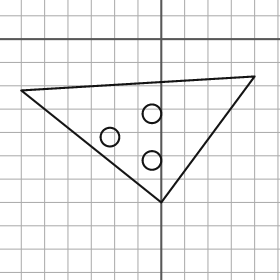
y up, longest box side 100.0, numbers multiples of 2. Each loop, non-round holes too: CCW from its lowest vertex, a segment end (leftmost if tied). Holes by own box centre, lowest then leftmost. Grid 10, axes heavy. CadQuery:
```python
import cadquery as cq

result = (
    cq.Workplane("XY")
    .moveTo(0.0, -70.0)
    .lineTo(40.0, -16.0)
    .lineTo(-60.0, -22.0)
    .close()
    .moveTo(-4.0, -52.0)
    .circle(4.0)
    .moveTo(-22.0, -42.0)
    .circle(4.0)
    .moveTo(-4.0, -32.0)
    .circle(4.0)
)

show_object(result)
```